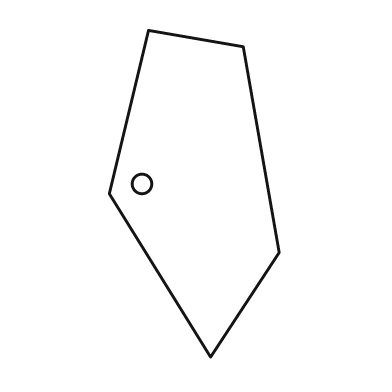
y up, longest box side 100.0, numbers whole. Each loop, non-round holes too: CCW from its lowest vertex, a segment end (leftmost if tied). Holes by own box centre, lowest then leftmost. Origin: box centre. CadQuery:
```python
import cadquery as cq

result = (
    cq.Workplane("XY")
    .moveTo(5.0, -50.0)
    .lineTo(26.0, -18.0)
    .lineTo(15.0, 45.0)
    .lineTo(-14.0, 50.0)
    .lineTo(-26.0, 0.0)
    .close()
    .moveTo(-16.0, 3.0)
    .circle(3.0)
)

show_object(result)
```